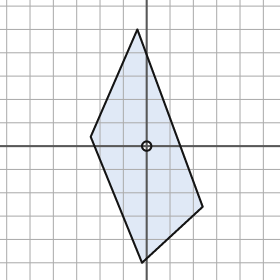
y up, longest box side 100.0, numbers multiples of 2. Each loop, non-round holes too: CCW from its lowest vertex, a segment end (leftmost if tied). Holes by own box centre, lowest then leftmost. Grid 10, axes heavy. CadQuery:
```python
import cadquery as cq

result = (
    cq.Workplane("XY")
    .moveTo(-2.0, -50.0)
    .lineTo(24.0, -26.0)
    .lineTo(-4.0, 50.0)
    .lineTo(-24.0, 4.0)
    .close()
    .moveTo(0.0, 0.0)
    .circle(2.0)
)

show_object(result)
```